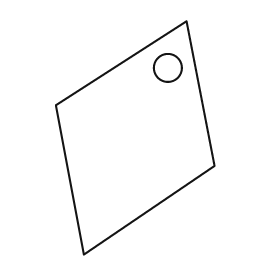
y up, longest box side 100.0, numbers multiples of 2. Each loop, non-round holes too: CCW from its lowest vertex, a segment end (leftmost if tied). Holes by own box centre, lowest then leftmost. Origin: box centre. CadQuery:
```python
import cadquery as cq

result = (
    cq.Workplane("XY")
    .moveTo(-22.0, -50.0)
    .lineTo(34.0, -12.0)
    .lineTo(22.0, 50.0)
    .lineTo(-34.0, 14.0)
    .close()
    .moveTo(14.0, 30.0)
    .circle(6.0)
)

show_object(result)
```